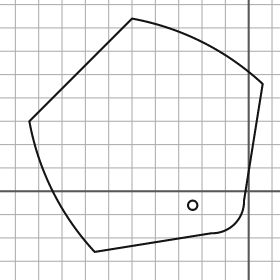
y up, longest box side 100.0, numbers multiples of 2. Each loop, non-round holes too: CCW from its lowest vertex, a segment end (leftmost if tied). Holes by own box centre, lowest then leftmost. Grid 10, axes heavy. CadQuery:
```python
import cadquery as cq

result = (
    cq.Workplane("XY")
    .moveTo(-66.0, -26.0)
    .lineTo(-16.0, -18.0)
    .threePointArc((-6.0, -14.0), (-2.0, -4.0))
    .lineTo(6.0, 46.0)
    .threePointArc((-20.0, 64.0), (-50.0, 74.0))
    .lineTo(-94.0, 30.0)
    .threePointArc((-84.0, 0.0), (-66.0, -26.0))
    .close()
    .moveTo(-24.0, -6.0)
    .circle(2.0)
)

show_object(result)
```